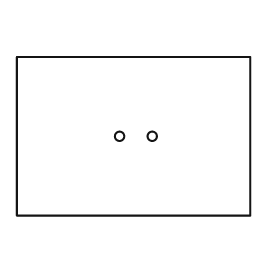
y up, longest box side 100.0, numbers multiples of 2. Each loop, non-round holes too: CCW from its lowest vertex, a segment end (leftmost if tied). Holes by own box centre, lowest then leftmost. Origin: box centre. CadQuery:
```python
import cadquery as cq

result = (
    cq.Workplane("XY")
    .moveTo(-50.0, -34.0)
    .lineTo(50.0, -34.0)
    .lineTo(50.0, 34.0)
    .lineTo(-50.0, 34.0)
    .close()
    .moveTo(-6.0, 0.0)
    .circle(2.0)
    .moveTo(8.0, 0.0)
    .circle(2.0)
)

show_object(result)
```